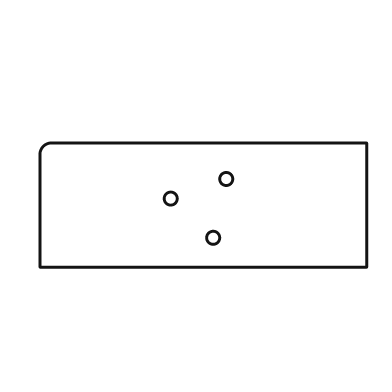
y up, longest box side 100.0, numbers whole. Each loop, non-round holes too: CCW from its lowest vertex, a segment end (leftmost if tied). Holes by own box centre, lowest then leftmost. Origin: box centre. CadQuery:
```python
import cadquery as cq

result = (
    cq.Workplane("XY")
    .moveTo(-50.0, -19.0)
    .lineTo(50.0, -19.0)
    .lineTo(50.0, 19.0)
    .lineTo(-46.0, 19.0)
    .threePointArc((-49.0, 18.0), (-50.0, 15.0))
    .close()
    .moveTo(3.0, -10.0)
    .circle(2.0)
    .moveTo(-10.0, 2.0)
    .circle(2.0)
    .moveTo(7.0, 8.0)
    .circle(2.0)
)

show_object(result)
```